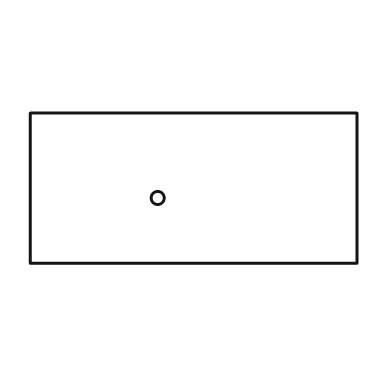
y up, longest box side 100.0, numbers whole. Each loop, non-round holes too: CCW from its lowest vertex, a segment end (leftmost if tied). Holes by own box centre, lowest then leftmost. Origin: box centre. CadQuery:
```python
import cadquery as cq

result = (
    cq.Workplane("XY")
    .moveTo(-50.0, -23.0)
    .lineTo(50.0, -23.0)
    .lineTo(50.0, 23.0)
    .lineTo(-50.0, 23.0)
    .close()
    .moveTo(-11.0, -3.0)
    .circle(2.0)
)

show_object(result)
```